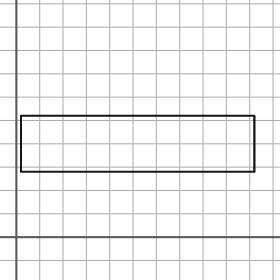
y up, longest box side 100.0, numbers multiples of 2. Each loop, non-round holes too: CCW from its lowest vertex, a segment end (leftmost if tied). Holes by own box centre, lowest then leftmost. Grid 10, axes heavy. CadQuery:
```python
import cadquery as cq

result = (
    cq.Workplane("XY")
    .moveTo(2.0, 28.0)
    .lineTo(102.0, 28.0)
    .lineTo(102.0, 52.0)
    .lineTo(2.0, 52.0)
    .close()
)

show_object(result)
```